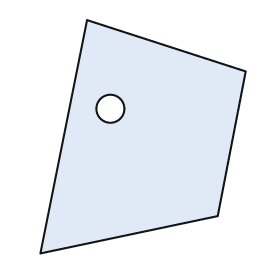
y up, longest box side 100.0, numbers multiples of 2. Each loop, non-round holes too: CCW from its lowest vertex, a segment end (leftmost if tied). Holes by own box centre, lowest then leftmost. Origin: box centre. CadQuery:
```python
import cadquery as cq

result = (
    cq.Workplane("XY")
    .moveTo(-44.0, -50.0)
    .lineTo(32.0, -34.0)
    .lineTo(44.0, 28.0)
    .lineTo(-24.0, 50.0)
    .close()
    .moveTo(-14.0, 12.0)
    .circle(6.0)
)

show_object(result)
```